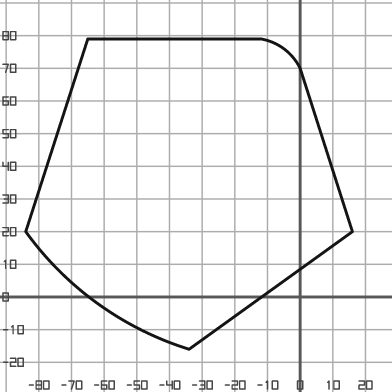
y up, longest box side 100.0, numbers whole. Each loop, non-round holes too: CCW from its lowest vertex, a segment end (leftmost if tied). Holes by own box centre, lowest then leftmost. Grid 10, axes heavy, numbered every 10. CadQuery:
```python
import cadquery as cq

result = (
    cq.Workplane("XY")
    .moveTo(-34.0, -16.0)
    .lineTo(16.0, 20.0)
    .lineTo(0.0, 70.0)
    .threePointArc((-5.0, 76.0), (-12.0, 79.0))
    .lineTo(-65.0, 79.0)
    .lineTo(-84.0, 20.0)
    .threePointArc((-62.0, -2.0), (-34.0, -16.0))
    .close()
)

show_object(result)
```